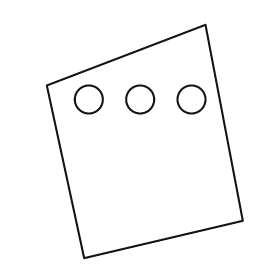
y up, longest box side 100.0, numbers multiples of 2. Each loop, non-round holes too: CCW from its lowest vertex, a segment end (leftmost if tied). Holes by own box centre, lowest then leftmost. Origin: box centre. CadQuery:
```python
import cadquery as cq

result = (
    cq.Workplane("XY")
    .moveTo(-26.0, -50.0)
    .lineTo(42.0, -34.0)
    .lineTo(26.0, 50.0)
    .lineTo(-42.0, 24.0)
    .close()
    .moveTo(-24.0, 18.0)
    .circle(6.0)
    .moveTo(-2.0, 18.0)
    .circle(6.0)
    .moveTo(20.0, 18.0)
    .circle(6.0)
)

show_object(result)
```